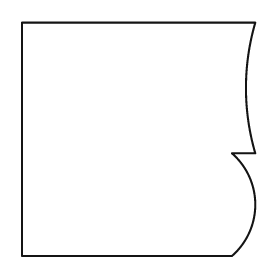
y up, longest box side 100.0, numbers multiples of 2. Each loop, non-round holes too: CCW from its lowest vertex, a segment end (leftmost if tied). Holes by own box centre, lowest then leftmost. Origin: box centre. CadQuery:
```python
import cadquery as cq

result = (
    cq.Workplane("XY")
    .moveTo(-50.0, -50.0)
    .lineTo(40.0, -50.0)
    .threePointArc((50.0, -28.0), (40.0, -6.0))
    .lineTo(50.0, -6.0)
    .threePointArc((46.0, 22.0), (50.0, 50.0))
    .lineTo(-50.0, 50.0)
    .close()
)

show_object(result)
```